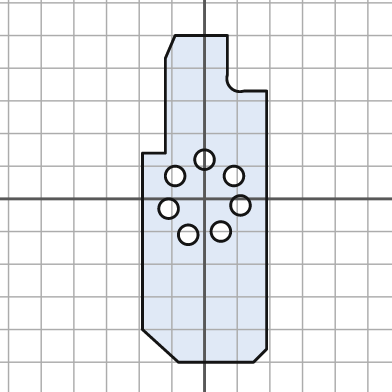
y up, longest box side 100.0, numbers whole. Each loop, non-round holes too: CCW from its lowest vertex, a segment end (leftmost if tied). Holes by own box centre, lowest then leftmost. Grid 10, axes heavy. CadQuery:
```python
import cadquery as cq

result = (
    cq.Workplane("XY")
    .moveTo(-8.0, -50.0)
    .lineTo(15.0, -50.0)
    .lineTo(19.0, -46.0)
    .lineTo(19.0, 33.0)
    .lineTo(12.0, 33.0)
    .threePointArc((8.0, 34.0), (7.0, 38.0))
    .lineTo(7.0, 50.0)
    .lineTo(-9.0, 50.0)
    .lineTo(-12.0, 43.0)
    .lineTo(-12.0, 14.0)
    .lineTo(-19.0, 14.0)
    .lineTo(-19.0, -40.0)
    .close()
    .moveTo(-5.0, -11.0)
    .circle(3.0)
    .moveTo(5.0, -10.0)
    .circle(3.0)
    .moveTo(-11.0, -3.0)
    .circle(3.0)
    .moveTo(11.0, -2.0)
    .circle(3.0)
    .moveTo(-9.0, 7.0)
    .circle(3.0)
    .moveTo(9.0, 7.0)
    .circle(3.0)
    .moveTo(0.0, 12.0)
    .circle(3.0)
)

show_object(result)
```